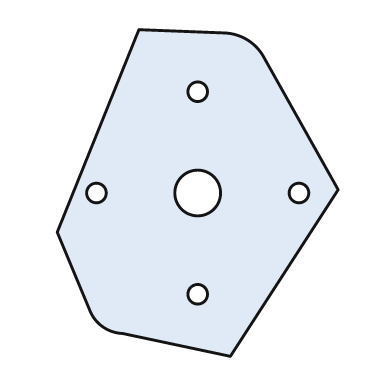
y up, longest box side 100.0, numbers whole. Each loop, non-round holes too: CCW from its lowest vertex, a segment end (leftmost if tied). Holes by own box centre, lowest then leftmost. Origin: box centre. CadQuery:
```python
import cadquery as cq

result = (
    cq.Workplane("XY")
    .moveTo(10.0, -50.0)
    .lineTo(43.0, 1.0)
    .lineTo(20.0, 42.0)
    .threePointArc((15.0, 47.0), (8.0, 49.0))
    .lineTo(-18.0, 50.0)
    .lineTo(-43.0, -12.0)
    .lineTo(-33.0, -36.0)
    .threePointArc((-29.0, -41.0), (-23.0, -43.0))
    .close()
    .moveTo(0.0, -31.0)
    .circle(3.0)
    .moveTo(-31.0, 0.0)
    .circle(3.0)
    .moveTo(0.0, 0.0)
    .circle(7.0)
    .moveTo(31.0, 0.0)
    .circle(3.0)
    .moveTo(0.0, 31.0)
    .circle(3.0)
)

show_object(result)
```